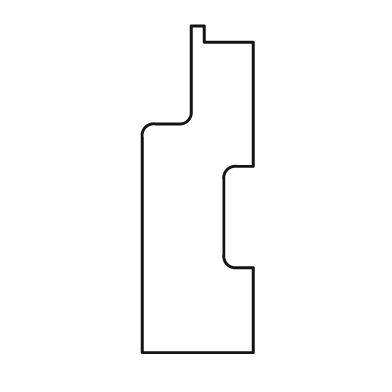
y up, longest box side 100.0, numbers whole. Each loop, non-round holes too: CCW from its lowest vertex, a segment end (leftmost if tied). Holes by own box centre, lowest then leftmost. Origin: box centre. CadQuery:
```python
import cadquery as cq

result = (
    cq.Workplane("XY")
    .moveTo(-17.0, -50.0)
    .lineTo(17.0, -50.0)
    .lineTo(17.0, -24.0)
    .lineTo(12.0, -24.0)
    .threePointArc((9.0, -23.0), (8.0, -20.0))
    .lineTo(8.0, 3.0)
    .threePointArc((9.0, 6.0), (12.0, 7.0))
    .lineTo(17.0, 7.0)
    .lineTo(17.0, 45.0)
    .lineTo(2.0, 45.0)
    .lineTo(2.0, 50.0)
    .lineTo(-2.0, 50.0)
    .lineTo(-2.0, 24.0)
    .threePointArc((-3.0, 21.0), (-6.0, 20.0))
    .lineTo(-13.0, 20.0)
    .threePointArc((-16.0, 19.0), (-17.0, 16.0))
    .close()
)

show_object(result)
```